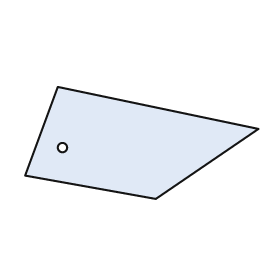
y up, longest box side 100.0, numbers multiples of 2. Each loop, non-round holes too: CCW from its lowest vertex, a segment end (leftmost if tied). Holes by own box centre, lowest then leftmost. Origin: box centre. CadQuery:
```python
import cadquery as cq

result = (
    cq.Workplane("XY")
    .moveTo(6.0, -24.0)
    .lineTo(50.0, 6.0)
    .lineTo(-36.0, 24.0)
    .lineTo(-50.0, -14.0)
    .close()
    .moveTo(-34.0, -2.0)
    .circle(2.0)
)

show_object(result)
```